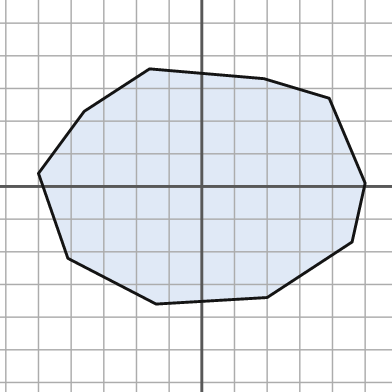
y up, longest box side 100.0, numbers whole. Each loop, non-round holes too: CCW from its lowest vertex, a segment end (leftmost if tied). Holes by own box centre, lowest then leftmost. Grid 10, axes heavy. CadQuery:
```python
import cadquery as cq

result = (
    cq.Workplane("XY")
    .moveTo(-14.0, -36.0)
    .lineTo(20.0, -34.0)
    .lineTo(46.0, -17.0)
    .lineTo(50.0, 1.0)
    .lineTo(39.0, 27.0)
    .lineTo(19.0, 33.0)
    .lineTo(-16.0, 36.0)
    .lineTo(-36.0, 23.0)
    .lineTo(-50.0, 4.0)
    .lineTo(-41.0, -22.0)
    .close()
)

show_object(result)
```